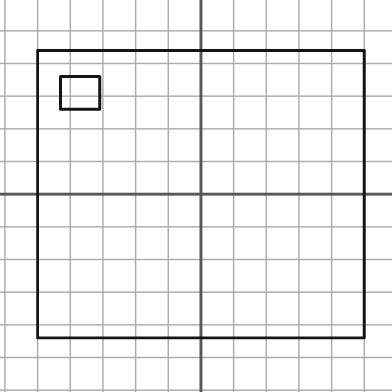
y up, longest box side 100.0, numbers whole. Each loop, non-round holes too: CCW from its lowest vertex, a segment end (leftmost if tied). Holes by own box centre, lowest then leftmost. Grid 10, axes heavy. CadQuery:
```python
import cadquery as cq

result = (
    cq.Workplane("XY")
    .moveTo(-50.0, -44.0)
    .lineTo(50.0, -44.0)
    .lineTo(50.0, 44.0)
    .lineTo(-50.0, 44.0)
    .close()
    .moveTo(-43.0, 26.0)
    .lineTo(-31.0, 26.0)
    .lineTo(-31.0, 36.0)
    .lineTo(-43.0, 36.0)
    .close()
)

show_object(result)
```